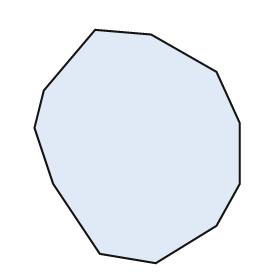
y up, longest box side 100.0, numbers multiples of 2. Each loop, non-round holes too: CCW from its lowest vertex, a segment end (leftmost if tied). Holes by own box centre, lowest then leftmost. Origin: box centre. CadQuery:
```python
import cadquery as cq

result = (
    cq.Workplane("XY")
    .moveTo(8.0, -50.0)
    .lineTo(34.0, -34.0)
    .lineTo(44.0, -16.0)
    .lineTo(44.0, 10.0)
    .lineTo(34.0, 32.0)
    .lineTo(6.0, 48.0)
    .lineTo(-18.0, 50.0)
    .lineTo(-40.0, 24.0)
    .lineTo(-44.0, 8.0)
    .lineTo(-36.0, -16.0)
    .lineTo(-16.0, -46.0)
    .close()
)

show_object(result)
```